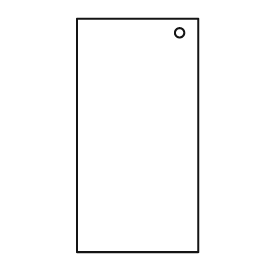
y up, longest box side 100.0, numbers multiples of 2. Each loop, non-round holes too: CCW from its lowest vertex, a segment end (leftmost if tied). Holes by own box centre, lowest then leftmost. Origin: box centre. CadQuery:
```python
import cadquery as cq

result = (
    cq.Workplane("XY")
    .moveTo(-26.0, -50.0)
    .lineTo(26.0, -50.0)
    .lineTo(26.0, 50.0)
    .lineTo(-26.0, 50.0)
    .close()
    .moveTo(18.0, 44.0)
    .circle(2.0)
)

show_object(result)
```